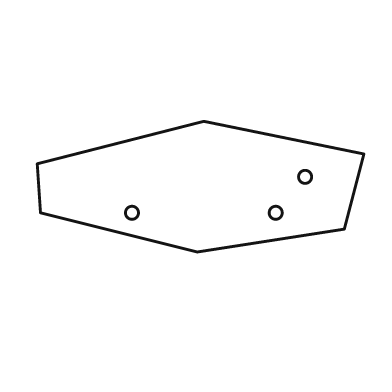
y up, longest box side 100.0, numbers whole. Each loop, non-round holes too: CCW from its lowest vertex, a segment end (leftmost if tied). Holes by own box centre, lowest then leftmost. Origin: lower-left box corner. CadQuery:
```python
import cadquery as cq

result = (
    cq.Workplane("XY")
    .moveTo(49.0, 0.0)
    .lineTo(94.0, 7.0)
    .lineTo(100.0, 30.0)
    .lineTo(51.0, 40.0)
    .lineTo(0.0, 27.0)
    .lineTo(1.0, 12.0)
    .close()
    .moveTo(29.0, 12.0)
    .circle(2.0)
    .moveTo(73.0, 12.0)
    .circle(2.0)
    .moveTo(82.0, 23.0)
    .circle(2.0)
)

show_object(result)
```